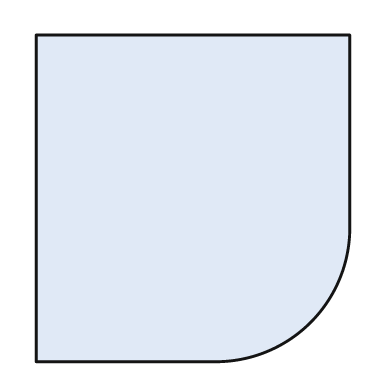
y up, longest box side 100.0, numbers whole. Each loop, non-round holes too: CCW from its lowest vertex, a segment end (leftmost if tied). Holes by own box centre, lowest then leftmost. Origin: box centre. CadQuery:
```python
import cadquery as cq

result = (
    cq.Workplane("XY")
    .moveTo(-48.0, -50.0)
    .lineTo(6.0, -50.0)
    .threePointArc((36.0, -38.0), (48.0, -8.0))
    .lineTo(48.0, 50.0)
    .lineTo(-48.0, 50.0)
    .close()
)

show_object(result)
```